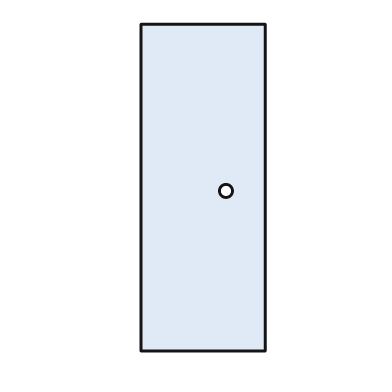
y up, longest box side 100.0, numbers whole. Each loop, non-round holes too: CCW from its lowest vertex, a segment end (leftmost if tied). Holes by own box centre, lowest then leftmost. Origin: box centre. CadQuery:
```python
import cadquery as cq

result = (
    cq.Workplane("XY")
    .moveTo(-19.0, -50.0)
    .lineTo(19.0, -50.0)
    .lineTo(19.0, 50.0)
    .lineTo(-19.0, 50.0)
    .close()
    .moveTo(7.0, -1.0)
    .circle(2.0)
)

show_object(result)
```